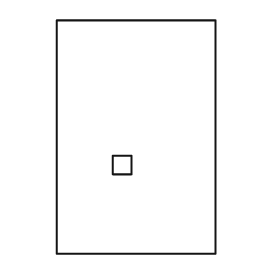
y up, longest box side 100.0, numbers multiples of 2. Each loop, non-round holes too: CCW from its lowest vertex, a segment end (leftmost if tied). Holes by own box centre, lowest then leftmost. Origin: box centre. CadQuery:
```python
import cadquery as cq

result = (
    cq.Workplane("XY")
    .moveTo(-34.0, -50.0)
    .lineTo(34.0, -50.0)
    .lineTo(34.0, 50.0)
    .lineTo(-34.0, 50.0)
    .close()
    .moveTo(-10.0, -16.0)
    .lineTo(-2.0, -16.0)
    .lineTo(-2.0, -8.0)
    .lineTo(-10.0, -8.0)
    .close()
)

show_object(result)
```